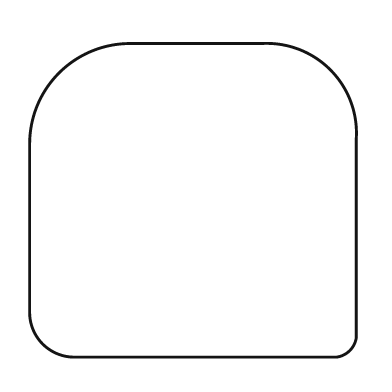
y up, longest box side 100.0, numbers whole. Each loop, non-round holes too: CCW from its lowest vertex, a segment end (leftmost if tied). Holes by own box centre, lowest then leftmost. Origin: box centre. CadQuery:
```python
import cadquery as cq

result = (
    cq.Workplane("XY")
    .moveTo(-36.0, -48.0)
    .lineTo(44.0, -48.0)
    .threePointArc((48.0, -46.0), (50.0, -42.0))
    .lineTo(50.0, 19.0)
    .threePointArc((42.0, 40.0), (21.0, 48.0))
    .lineTo(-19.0, 48.0)
    .threePointArc((-41.0, 39.0), (-50.0, 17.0))
    .lineTo(-50.0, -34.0)
    .threePointArc((-46.0, -44.0), (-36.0, -48.0))
    .close()
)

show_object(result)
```